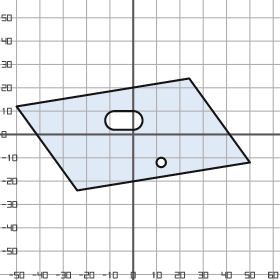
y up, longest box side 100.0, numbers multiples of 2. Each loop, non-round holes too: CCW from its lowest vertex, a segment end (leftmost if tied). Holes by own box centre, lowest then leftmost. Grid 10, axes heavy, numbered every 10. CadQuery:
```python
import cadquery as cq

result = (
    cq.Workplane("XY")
    .moveTo(-24.0, -24.0)
    .lineTo(50.0, -12.0)
    .lineTo(24.0, 24.0)
    .lineTo(-50.0, 12.0)
    .close()
    .moveTo(12.0, -12.0)
    .circle(2.0)
    .moveTo(-8.0, 2.0)
    .lineTo(0.0, 2.0)
    .threePointArc((4.0, 6.0), (0.0, 10.0))
    .lineTo(-8.0, 10.0)
    .threePointArc((-12.0, 6.0), (-8.0, 2.0))
    .close()
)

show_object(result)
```